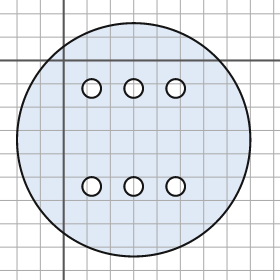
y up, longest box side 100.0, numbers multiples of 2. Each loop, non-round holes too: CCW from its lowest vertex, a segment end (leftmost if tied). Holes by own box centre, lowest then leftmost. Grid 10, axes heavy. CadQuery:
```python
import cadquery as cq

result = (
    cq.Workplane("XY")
    .moveTo(30.0, -34.0)
    .circle(50.0)
    .moveTo(12.0, -54.0)
    .circle(4.0)
    .moveTo(30.0, -54.0)
    .circle(4.0)
    .moveTo(48.0, -54.0)
    .circle(4.0)
    .moveTo(12.0, -12.0)
    .circle(4.0)
    .moveTo(30.0, -12.0)
    .circle(4.0)
    .moveTo(48.0, -12.0)
    .circle(4.0)
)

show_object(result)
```